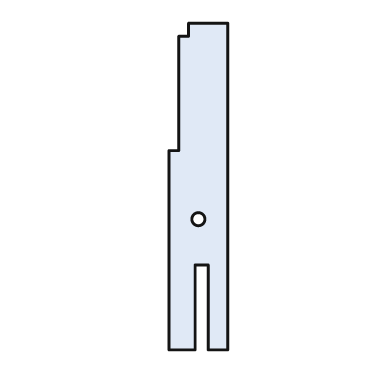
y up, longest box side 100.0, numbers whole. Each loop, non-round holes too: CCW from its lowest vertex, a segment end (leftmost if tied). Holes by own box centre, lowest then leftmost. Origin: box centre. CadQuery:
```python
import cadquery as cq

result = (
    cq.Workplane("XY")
    .moveTo(-9.0, -50.0)
    .lineTo(-1.0, -50.0)
    .lineTo(-1.0, -24.0)
    .lineTo(3.0, -24.0)
    .lineTo(3.0, -50.0)
    .lineTo(9.0, -50.0)
    .lineTo(9.0, 50.0)
    .lineTo(-3.0, 50.0)
    .lineTo(-3.0, 46.0)
    .lineTo(-6.0, 46.0)
    .lineTo(-6.0, 11.0)
    .lineTo(-9.0, 11.0)
    .close()
    .moveTo(0.0, -10.0)
    .circle(2.0)
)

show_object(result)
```